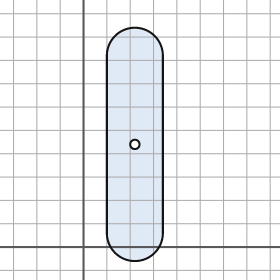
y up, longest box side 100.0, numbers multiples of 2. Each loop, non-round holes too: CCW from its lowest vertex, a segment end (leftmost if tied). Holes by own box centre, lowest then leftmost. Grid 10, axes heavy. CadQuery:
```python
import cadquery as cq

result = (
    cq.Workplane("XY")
    .moveTo(10.0, 6.0)
    .threePointArc((22.0, -6.0), (34.0, 6.0))
    .lineTo(34.0, 82.0)
    .threePointArc((22.0, 94.0), (10.0, 82.0))
    .close()
    .moveTo(22.0, 44.0)
    .circle(2.0)
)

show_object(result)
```